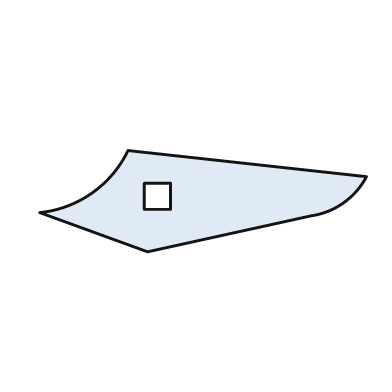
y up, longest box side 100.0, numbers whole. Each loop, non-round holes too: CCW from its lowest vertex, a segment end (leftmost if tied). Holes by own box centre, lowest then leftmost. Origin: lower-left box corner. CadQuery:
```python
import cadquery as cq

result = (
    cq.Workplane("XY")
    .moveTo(33.0, 0.0)
    .lineTo(83.0, 11.0)
    .threePointArc((93.0, 15.0), (100.0, 23.0))
    .lineTo(27.0, 31.0)
    .threePointArc((16.0, 18.0), (0.0, 12.0))
    .close()
    .moveTo(32.0, 13.0)
    .lineTo(40.0, 13.0)
    .lineTo(40.0, 21.0)
    .lineTo(32.0, 21.0)
    .close()
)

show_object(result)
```